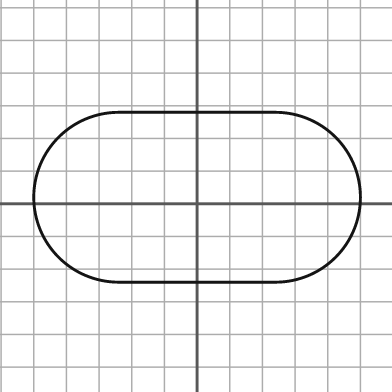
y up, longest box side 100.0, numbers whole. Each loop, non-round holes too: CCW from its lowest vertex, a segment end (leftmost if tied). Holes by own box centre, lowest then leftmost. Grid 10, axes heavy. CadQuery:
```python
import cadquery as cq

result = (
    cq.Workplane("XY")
    .moveTo(-24.0, -24.0)
    .lineTo(24.0, -24.0)
    .threePointArc((50.0, 2.0), (24.0, 28.0))
    .lineTo(-24.0, 28.0)
    .threePointArc((-50.0, 2.0), (-24.0, -24.0))
    .close()
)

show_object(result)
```